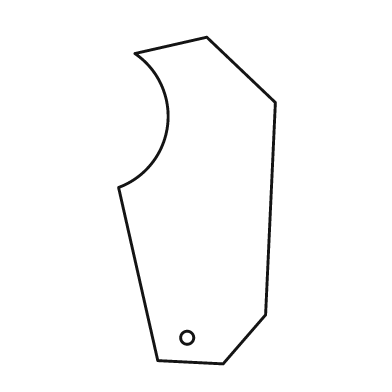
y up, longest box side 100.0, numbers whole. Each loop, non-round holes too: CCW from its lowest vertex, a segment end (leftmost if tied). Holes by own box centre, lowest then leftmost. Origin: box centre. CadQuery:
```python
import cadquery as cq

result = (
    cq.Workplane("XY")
    .moveTo(8.0, -50.0)
    .lineTo(21.0, -35.0)
    .lineTo(24.0, 30.0)
    .lineTo(3.0, 50.0)
    .lineTo(-19.0, 45.0)
    .threePointArc((-9.0, 23.0), (-24.0, 4.0))
    .lineTo(-12.0, -49.0)
    .close()
    .moveTo(-3.0, -42.0)
    .circle(2.0)
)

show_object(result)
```